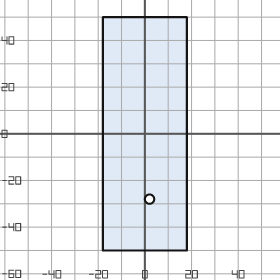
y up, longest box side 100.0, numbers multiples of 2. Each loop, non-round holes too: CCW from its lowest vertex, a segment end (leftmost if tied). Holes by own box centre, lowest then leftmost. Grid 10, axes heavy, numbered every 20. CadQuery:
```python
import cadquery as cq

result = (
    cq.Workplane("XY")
    .moveTo(-18.0, -50.0)
    .lineTo(18.0, -50.0)
    .lineTo(18.0, 50.0)
    .lineTo(-18.0, 50.0)
    .close()
    .moveTo(2.0, -28.0)
    .circle(2.0)
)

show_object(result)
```